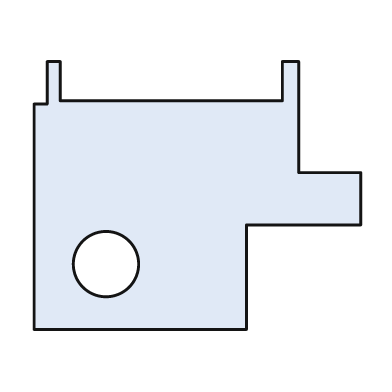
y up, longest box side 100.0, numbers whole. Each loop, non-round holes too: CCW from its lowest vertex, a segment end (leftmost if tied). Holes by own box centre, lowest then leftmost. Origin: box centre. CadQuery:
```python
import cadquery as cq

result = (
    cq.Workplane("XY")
    .moveTo(-50.0, -41.0)
    .lineTo(15.0, -41.0)
    .lineTo(15.0, -9.0)
    .lineTo(50.0, -9.0)
    .lineTo(50.0, 7.0)
    .lineTo(31.0, 7.0)
    .lineTo(31.0, 41.0)
    .lineTo(26.0, 41.0)
    .lineTo(26.0, 29.0)
    .lineTo(-42.0, 29.0)
    .lineTo(-42.0, 41.0)
    .lineTo(-46.0, 41.0)
    .lineTo(-46.0, 28.0)
    .lineTo(-50.0, 28.0)
    .close()
    .moveTo(-28.0, -21.0)
    .circle(10.0)
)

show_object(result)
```